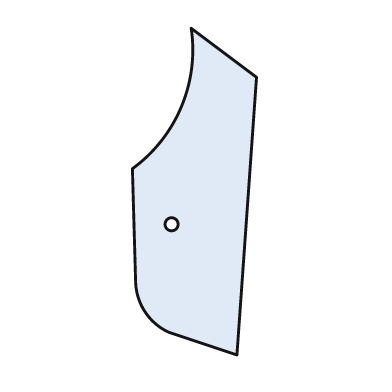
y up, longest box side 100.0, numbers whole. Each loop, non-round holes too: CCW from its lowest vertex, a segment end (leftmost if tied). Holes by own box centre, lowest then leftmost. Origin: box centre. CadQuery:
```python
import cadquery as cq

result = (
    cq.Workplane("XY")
    .moveTo(13.0, -50.0)
    .lineTo(19.0, 35.0)
    .lineTo(-1.0, 50.0)
    .threePointArc((-4.0, 26.0), (-19.0, 7.0))
    .lineTo(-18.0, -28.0)
    .threePointArc((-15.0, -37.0), (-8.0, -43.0))
    .close()
    .moveTo(-7.0, -10.0)
    .circle(2.0)
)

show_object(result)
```